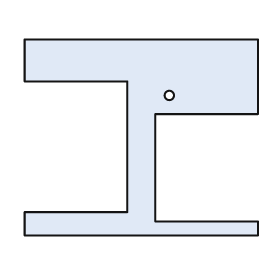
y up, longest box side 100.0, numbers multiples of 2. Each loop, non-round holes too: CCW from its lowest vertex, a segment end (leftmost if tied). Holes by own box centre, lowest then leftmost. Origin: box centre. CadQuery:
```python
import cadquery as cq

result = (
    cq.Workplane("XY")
    .moveTo(-50.0, -42.0)
    .lineTo(50.0, -42.0)
    .lineTo(50.0, -36.0)
    .lineTo(6.0, -36.0)
    .lineTo(6.0, 10.0)
    .lineTo(50.0, 10.0)
    .lineTo(50.0, 42.0)
    .lineTo(-50.0, 42.0)
    .lineTo(-50.0, 24.0)
    .lineTo(-6.0, 24.0)
    .lineTo(-6.0, -32.0)
    .lineTo(-50.0, -32.0)
    .close()
    .moveTo(12.0, 18.0)
    .circle(2.0)
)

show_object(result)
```